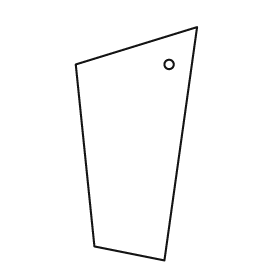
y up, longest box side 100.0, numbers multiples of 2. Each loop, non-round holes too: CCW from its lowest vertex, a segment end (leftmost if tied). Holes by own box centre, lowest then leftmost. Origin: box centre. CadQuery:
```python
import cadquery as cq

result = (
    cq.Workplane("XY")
    .moveTo(12.0, -50.0)
    .lineTo(26.0, 50.0)
    .lineTo(-26.0, 34.0)
    .lineTo(-18.0, -44.0)
    .close()
    .moveTo(14.0, 34.0)
    .circle(2.0)
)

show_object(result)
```